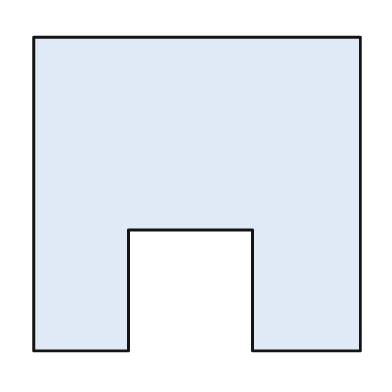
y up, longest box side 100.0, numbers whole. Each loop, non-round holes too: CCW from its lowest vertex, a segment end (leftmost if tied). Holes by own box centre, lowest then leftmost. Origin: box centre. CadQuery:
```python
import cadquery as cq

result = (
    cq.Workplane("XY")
    .moveTo(-50.0, -48.0)
    .lineTo(-21.0, -48.0)
    .lineTo(-21.0, -11.0)
    .lineTo(17.0, -11.0)
    .lineTo(17.0, -48.0)
    .lineTo(50.0, -48.0)
    .lineTo(50.0, 48.0)
    .lineTo(-50.0, 48.0)
    .close()
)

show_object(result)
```